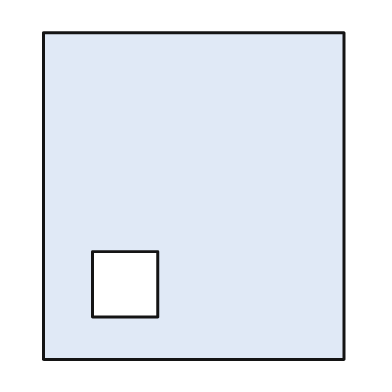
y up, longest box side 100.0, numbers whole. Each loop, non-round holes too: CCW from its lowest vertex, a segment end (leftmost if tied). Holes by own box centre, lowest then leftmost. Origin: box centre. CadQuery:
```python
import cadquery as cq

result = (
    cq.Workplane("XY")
    .moveTo(-46.0, -50.0)
    .lineTo(46.0, -50.0)
    .lineTo(46.0, 50.0)
    .lineTo(-46.0, 50.0)
    .close()
    .moveTo(-31.0, -37.0)
    .lineTo(-11.0, -37.0)
    .lineTo(-11.0, -17.0)
    .lineTo(-31.0, -17.0)
    .close()
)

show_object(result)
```